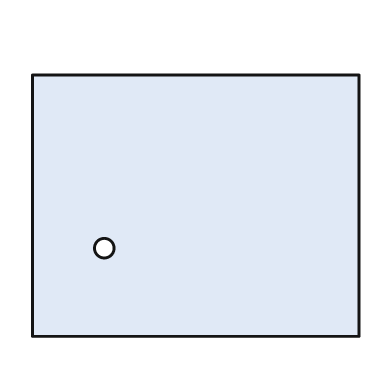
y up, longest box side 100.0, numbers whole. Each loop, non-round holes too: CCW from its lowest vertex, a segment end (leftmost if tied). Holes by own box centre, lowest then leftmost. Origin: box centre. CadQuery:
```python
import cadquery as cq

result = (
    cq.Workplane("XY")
    .moveTo(-50.0, -40.0)
    .lineTo(50.0, -40.0)
    .lineTo(50.0, 40.0)
    .lineTo(-50.0, 40.0)
    .close()
    .moveTo(-28.0, -13.0)
    .circle(3.0)
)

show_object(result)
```